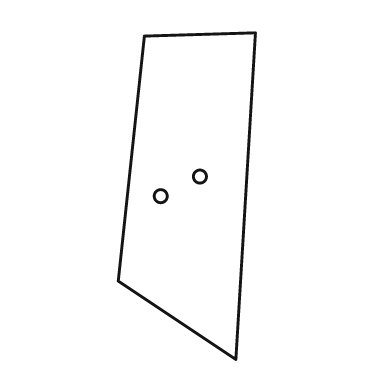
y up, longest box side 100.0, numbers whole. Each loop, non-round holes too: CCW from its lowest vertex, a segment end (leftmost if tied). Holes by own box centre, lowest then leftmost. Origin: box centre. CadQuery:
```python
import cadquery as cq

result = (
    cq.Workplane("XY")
    .moveTo(15.0, -50.0)
    .lineTo(21.0, 50.0)
    .lineTo(-13.0, 49.0)
    .lineTo(-21.0, -26.0)
    .close()
    .moveTo(-8.0, 0.0)
    .circle(2.0)
    .moveTo(4.0, 6.0)
    .circle(2.0)
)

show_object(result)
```